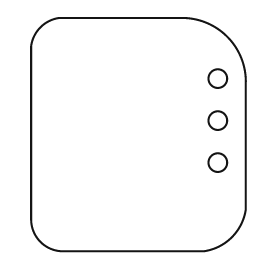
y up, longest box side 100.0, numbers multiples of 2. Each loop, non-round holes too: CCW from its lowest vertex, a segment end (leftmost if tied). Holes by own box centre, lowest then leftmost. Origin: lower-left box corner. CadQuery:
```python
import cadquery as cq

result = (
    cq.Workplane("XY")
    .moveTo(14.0, 0.0)
    .lineTo(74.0, 0.0)
    .threePointArc((86.0, 6.0), (92.0, 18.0))
    .lineTo(92.0, 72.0)
    .threePointArc((84.0, 92.0), (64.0, 100.0))
    .lineTo(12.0, 100.0)
    .threePointArc((4.0, 96.0), (0.0, 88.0))
    .lineTo(0.0, 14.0)
    .threePointArc((4.0, 4.0), (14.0, 0.0))
    .close()
    .moveTo(80.0, 38.0)
    .circle(4.0)
    .moveTo(80.0, 56.0)
    .circle(4.0)
    .moveTo(80.0, 74.0)
    .circle(4.0)
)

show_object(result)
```